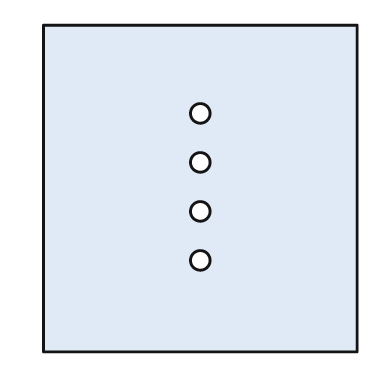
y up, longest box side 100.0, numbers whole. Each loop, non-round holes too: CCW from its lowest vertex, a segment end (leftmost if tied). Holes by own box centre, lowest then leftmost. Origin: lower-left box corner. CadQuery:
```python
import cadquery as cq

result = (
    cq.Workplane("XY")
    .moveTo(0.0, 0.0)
    .lineTo(96.0, 0.0)
    .lineTo(96.0, 100.0)
    .lineTo(0.0, 100.0)
    .close()
    .moveTo(48.0, 28.0)
    .circle(3.0)
    .moveTo(48.0, 43.0)
    .circle(3.0)
    .moveTo(48.0, 58.0)
    .circle(3.0)
    .moveTo(48.0, 73.0)
    .circle(3.0)
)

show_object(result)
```